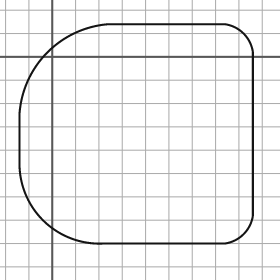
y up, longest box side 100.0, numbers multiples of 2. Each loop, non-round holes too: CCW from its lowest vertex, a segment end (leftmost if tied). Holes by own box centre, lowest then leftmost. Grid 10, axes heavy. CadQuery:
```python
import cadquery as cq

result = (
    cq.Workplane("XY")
    .moveTo(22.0, -80.0)
    .lineTo(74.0, -80.0)
    .threePointArc((82.0, -76.0), (86.0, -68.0))
    .lineTo(86.0, 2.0)
    .threePointArc((82.0, 10.0), (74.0, 14.0))
    .lineTo(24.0, 14.0)
    .threePointArc((-2.0, 2.0), (-14.0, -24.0))
    .lineTo(-14.0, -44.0)
    .threePointArc((-4.0, -70.0), (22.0, -80.0))
    .close()
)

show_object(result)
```